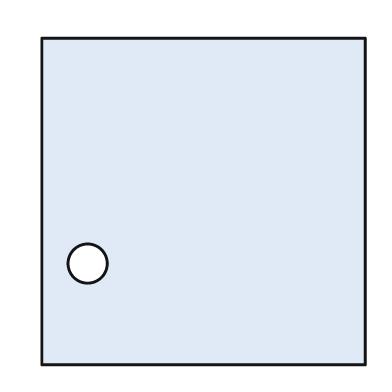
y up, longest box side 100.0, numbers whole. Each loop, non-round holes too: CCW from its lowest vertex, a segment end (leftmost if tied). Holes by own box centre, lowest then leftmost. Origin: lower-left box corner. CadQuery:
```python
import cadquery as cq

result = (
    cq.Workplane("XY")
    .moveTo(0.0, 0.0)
    .lineTo(99.0, 0.0)
    .lineTo(99.0, 100.0)
    .lineTo(0.0, 100.0)
    .close()
    .moveTo(14.0, 31.0)
    .circle(6.0)
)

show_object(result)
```